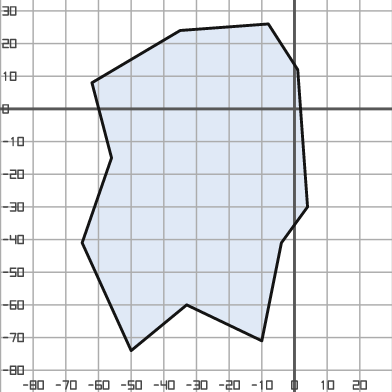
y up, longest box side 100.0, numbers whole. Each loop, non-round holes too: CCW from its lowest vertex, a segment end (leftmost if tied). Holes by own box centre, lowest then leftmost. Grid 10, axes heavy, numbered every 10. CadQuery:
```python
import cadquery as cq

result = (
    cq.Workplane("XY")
    .moveTo(-50.0, -74.0)
    .lineTo(-33.0, -60.0)
    .lineTo(-10.0, -71.0)
    .lineTo(-4.0, -41.0)
    .lineTo(4.0, -30.0)
    .lineTo(1.0, 12.0)
    .lineTo(-8.0, 26.0)
    .lineTo(-35.0, 24.0)
    .lineTo(-62.0, 8.0)
    .lineTo(-56.0, -15.0)
    .lineTo(-65.0, -41.0)
    .close()
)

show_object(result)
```